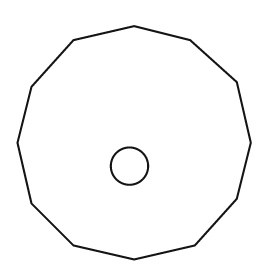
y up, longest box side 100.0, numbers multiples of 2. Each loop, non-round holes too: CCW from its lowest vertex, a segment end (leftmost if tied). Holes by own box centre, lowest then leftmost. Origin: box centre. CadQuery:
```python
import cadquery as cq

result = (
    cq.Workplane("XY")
    .moveTo(0.0, -50.0)
    .lineTo(26.0, -44.0)
    .lineTo(44.0, -24.0)
    .lineTo(50.0, 0.0)
    .lineTo(44.0, 26.0)
    .lineTo(24.0, 44.0)
    .lineTo(0.0, 50.0)
    .lineTo(-26.0, 44.0)
    .lineTo(-44.0, 24.0)
    .lineTo(-50.0, 0.0)
    .lineTo(-44.0, -26.0)
    .lineTo(-26.0, -44.0)
    .close()
    .moveTo(-2.0, -10.0)
    .circle(8.0)
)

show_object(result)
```